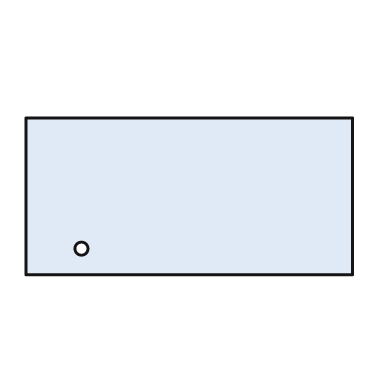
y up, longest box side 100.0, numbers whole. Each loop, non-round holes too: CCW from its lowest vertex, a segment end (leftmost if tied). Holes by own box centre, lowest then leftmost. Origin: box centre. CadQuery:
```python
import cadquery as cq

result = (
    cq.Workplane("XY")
    .moveTo(-50.0, -24.0)
    .lineTo(50.0, -24.0)
    .lineTo(50.0, 24.0)
    .lineTo(-50.0, 24.0)
    .close()
    .moveTo(-33.0, -16.0)
    .circle(2.0)
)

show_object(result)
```